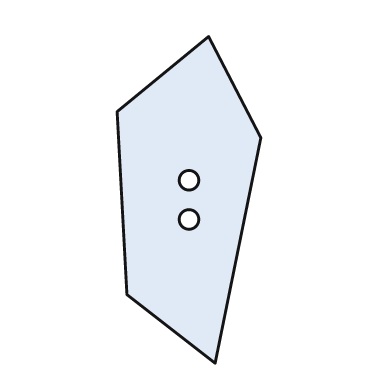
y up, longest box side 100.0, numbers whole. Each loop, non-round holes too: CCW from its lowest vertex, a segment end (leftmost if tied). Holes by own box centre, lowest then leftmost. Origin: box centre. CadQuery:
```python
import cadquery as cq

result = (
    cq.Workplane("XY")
    .moveTo(8.0, -50.0)
    .lineTo(22.0, 19.0)
    .lineTo(6.0, 50.0)
    .lineTo(-22.0, 27.0)
    .lineTo(-19.0, -29.0)
    .close()
    .moveTo(0.0, -6.0)
    .circle(3.0)
    .moveTo(0.0, 6.0)
    .circle(3.0)
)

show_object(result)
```